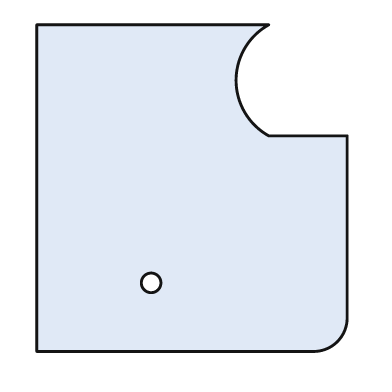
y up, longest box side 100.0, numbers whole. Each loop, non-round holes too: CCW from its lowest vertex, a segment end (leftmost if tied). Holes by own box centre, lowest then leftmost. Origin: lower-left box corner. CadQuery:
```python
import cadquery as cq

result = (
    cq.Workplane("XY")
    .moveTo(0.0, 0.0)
    .lineTo(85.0, 0.0)
    .threePointArc((92.0, 3.0), (95.0, 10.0))
    .lineTo(95.0, 66.0)
    .lineTo(71.0, 66.0)
    .threePointArc((61.0, 83.0), (71.0, 100.0))
    .lineTo(0.0, 100.0)
    .close()
    .moveTo(35.0, 21.0)
    .circle(3.0)
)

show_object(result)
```